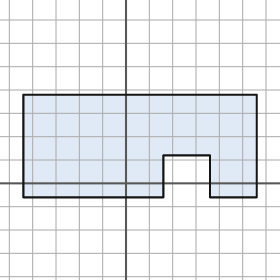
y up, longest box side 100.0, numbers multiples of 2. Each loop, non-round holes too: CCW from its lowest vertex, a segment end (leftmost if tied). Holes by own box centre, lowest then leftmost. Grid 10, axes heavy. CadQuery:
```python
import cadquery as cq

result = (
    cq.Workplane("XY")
    .moveTo(-44.0, -6.0)
    .lineTo(16.0, -6.0)
    .lineTo(16.0, 12.0)
    .lineTo(36.0, 12.0)
    .lineTo(36.0, -6.0)
    .lineTo(56.0, -6.0)
    .lineTo(56.0, 38.0)
    .lineTo(-44.0, 38.0)
    .close()
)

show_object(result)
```